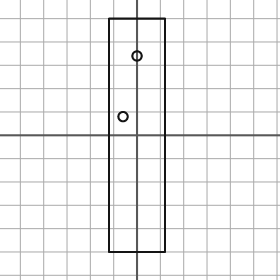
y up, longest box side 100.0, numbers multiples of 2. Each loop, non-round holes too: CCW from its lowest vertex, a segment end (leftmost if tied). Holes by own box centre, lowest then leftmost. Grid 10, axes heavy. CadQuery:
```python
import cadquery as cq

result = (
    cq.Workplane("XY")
    .moveTo(-12.0, -50.0)
    .lineTo(12.0, -50.0)
    .lineTo(12.0, 50.0)
    .lineTo(-12.0, 50.0)
    .close()
    .moveTo(-6.0, 8.0)
    .circle(2.0)
    .moveTo(0.0, 34.0)
    .circle(2.0)
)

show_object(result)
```